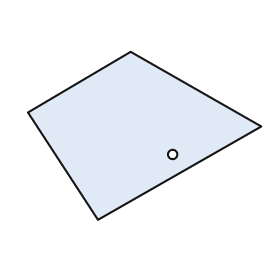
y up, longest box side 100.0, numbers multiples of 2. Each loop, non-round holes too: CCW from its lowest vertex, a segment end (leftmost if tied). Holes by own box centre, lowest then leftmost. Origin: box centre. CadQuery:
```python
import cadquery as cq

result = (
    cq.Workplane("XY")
    .moveTo(-20.0, -36.0)
    .lineTo(50.0, 4.0)
    .lineTo(-6.0, 36.0)
    .lineTo(-50.0, 10.0)
    .close()
    .moveTo(12.0, -8.0)
    .circle(2.0)
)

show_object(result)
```